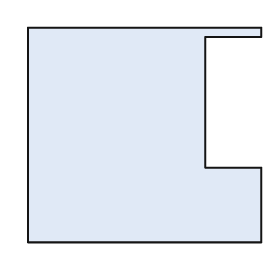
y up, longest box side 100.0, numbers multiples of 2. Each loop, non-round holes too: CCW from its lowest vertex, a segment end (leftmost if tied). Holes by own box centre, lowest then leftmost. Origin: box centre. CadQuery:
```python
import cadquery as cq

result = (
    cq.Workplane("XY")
    .moveTo(-50.0, -46.0)
    .lineTo(50.0, -46.0)
    .lineTo(50.0, -14.0)
    .lineTo(26.0, -14.0)
    .lineTo(26.0, 42.0)
    .lineTo(50.0, 42.0)
    .lineTo(50.0, 46.0)
    .lineTo(-50.0, 46.0)
    .close()
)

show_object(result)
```